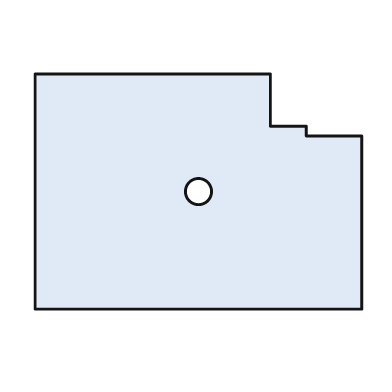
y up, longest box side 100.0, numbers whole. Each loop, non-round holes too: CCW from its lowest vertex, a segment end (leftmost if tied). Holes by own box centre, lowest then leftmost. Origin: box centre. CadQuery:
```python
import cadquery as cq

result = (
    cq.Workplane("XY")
    .moveTo(-50.0, -36.0)
    .lineTo(50.0, -36.0)
    .lineTo(50.0, 17.0)
    .lineTo(33.0, 17.0)
    .lineTo(33.0, 20.0)
    .lineTo(22.0, 20.0)
    .lineTo(22.0, 36.0)
    .lineTo(-50.0, 36.0)
    .close()
    .moveTo(0.0, 0.0)
    .circle(4.0)
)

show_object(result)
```